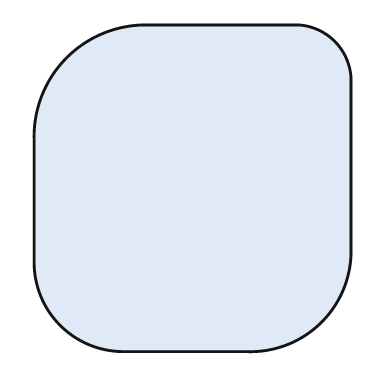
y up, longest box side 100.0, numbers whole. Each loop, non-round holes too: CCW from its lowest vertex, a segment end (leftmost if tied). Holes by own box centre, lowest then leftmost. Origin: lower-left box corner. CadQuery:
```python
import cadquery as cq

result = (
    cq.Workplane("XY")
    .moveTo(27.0, 0.0)
    .lineTo(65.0, 0.0)
    .threePointArc((88.0, 9.0), (97.0, 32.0))
    .lineTo(97.0, 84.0)
    .threePointArc((92.0, 95.0), (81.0, 100.0))
    .lineTo(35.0, 100.0)
    .threePointArc((10.0, 90.0), (0.0, 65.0))
    .lineTo(0.0, 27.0)
    .threePointArc((8.0, 8.0), (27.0, 0.0))
    .close()
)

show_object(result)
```